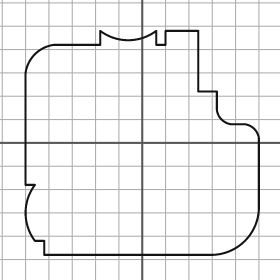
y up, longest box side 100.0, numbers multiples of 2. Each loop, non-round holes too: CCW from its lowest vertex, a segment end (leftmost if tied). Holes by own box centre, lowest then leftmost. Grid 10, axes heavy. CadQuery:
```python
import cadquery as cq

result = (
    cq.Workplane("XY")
    .moveTo(-42.0, -48.0)
    .lineTo(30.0, -48.0)
    .threePointArc((44.0, -42.0), (50.0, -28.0))
    .lineTo(50.0, 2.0)
    .threePointArc((48.0, 6.0), (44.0, 8.0))
    .lineTo(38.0, 8.0)
    .threePointArc((34.0, 10.0), (32.0, 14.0))
    .lineTo(32.0, 22.0)
    .lineTo(24.0, 22.0)
    .lineTo(24.0, 48.0)
    .lineTo(10.0, 48.0)
    .lineTo(10.0, 42.0)
    .lineTo(6.0, 42.0)
    .lineTo(6.0, 48.0)
    .threePointArc((-6.0, 44.0), (-18.0, 48.0))
    .lineTo(-18.0, 42.0)
    .lineTo(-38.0, 42.0)
    .threePointArc((-46.0, 38.0), (-50.0, 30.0))
    .lineTo(-50.0, -18.0)
    .lineTo(-46.0, -18.0)
    .threePointArc((-50.0, -30.0), (-46.0, -42.0))
    .lineTo(-42.0, -42.0)
    .close()
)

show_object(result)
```